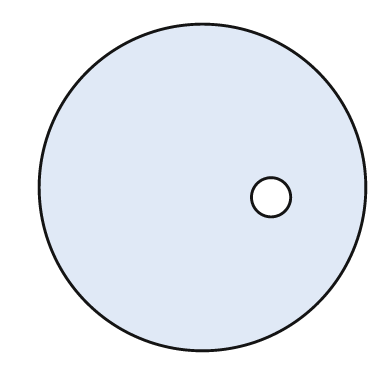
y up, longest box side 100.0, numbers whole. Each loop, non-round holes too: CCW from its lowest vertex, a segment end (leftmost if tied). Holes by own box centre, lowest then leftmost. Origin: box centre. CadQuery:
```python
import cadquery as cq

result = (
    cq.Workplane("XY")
    .moveTo(0.0, 0.0)
    .circle(50.0)
    .moveTo(21.0, -3.0)
    .circle(6.0)
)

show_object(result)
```